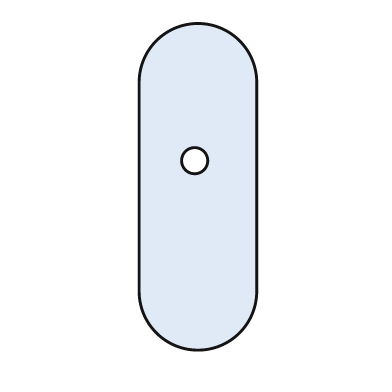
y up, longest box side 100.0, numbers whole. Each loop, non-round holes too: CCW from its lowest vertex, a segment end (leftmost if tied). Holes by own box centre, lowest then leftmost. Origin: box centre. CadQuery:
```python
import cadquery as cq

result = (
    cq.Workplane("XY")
    .moveTo(-18.0, -32.0)
    .threePointArc((0.0, -50.0), (18.0, -32.0))
    .lineTo(18.0, 32.0)
    .threePointArc((0.0, 50.0), (-18.0, 32.0))
    .close()
    .moveTo(-1.0, 8.0)
    .circle(4.0)
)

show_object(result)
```